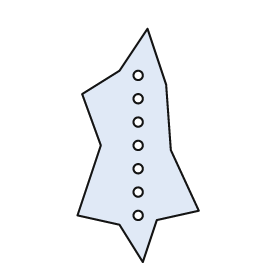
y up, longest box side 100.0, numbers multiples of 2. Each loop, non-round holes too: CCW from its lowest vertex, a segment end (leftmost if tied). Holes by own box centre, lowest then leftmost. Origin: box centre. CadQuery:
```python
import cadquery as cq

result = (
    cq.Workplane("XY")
    .moveTo(2.0, -50.0)
    .lineTo(8.0, -32.0)
    .lineTo(26.0, -28.0)
    .lineTo(14.0, -2.0)
    .lineTo(12.0, 26.0)
    .lineTo(4.0, 50.0)
    .lineTo(-8.0, 32.0)
    .lineTo(-24.0, 22.0)
    .lineTo(-16.0, 0.0)
    .lineTo(-26.0, -30.0)
    .lineTo(-8.0, -34.0)
    .close()
    .moveTo(0.0, -30.0)
    .circle(2.0)
    .moveTo(0.0, -20.0)
    .circle(2.0)
    .moveTo(0.0, -10.0)
    .circle(2.0)
    .moveTo(0.0, 0.0)
    .circle(2.0)
    .moveTo(0.0, 10.0)
    .circle(2.0)
    .moveTo(0.0, 20.0)
    .circle(2.0)
    .moveTo(0.0, 30.0)
    .circle(2.0)
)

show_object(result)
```